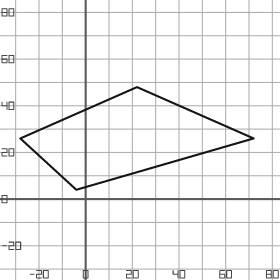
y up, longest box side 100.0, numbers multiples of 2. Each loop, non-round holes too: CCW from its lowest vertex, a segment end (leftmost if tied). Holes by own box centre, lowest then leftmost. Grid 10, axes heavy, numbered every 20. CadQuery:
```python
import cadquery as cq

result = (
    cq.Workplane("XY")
    .moveTo(-4.0, 4.0)
    .lineTo(72.0, 26.0)
    .lineTo(22.0, 48.0)
    .lineTo(-28.0, 26.0)
    .close()
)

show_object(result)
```